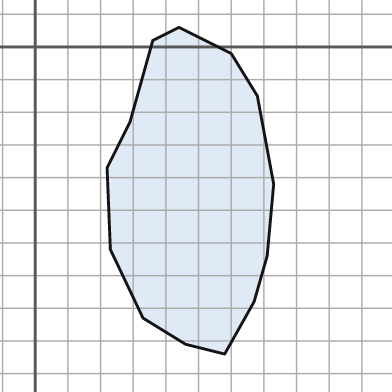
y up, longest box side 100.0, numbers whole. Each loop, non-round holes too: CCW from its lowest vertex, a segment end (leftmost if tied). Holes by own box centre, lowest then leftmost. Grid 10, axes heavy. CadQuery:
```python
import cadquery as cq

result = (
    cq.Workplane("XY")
    .moveTo(58.0, -94.0)
    .lineTo(67.0, -78.0)
    .lineTo(71.0, -64.0)
    .lineTo(73.0, -42.0)
    .lineTo(68.0, -15.0)
    .lineTo(60.0, -2.0)
    .lineTo(44.0, 6.0)
    .lineTo(36.0, 2.0)
    .lineTo(29.0, -23.0)
    .lineTo(22.0, -37.0)
    .lineTo(23.0, -62.0)
    .lineTo(33.0, -83.0)
    .lineTo(46.0, -91.0)
    .close()
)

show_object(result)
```